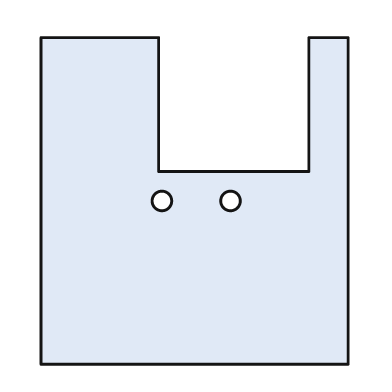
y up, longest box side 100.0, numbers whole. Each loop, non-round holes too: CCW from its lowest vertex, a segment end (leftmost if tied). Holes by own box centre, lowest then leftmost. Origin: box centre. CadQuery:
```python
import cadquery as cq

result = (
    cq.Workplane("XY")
    .moveTo(-47.0, -50.0)
    .lineTo(47.0, -50.0)
    .lineTo(47.0, 50.0)
    .lineTo(35.0, 50.0)
    .lineTo(35.0, 9.0)
    .lineTo(-11.0, 9.0)
    .lineTo(-11.0, 50.0)
    .lineTo(-47.0, 50.0)
    .close()
    .moveTo(-10.0, 0.0)
    .circle(3.0)
    .moveTo(11.0, 0.0)
    .circle(3.0)
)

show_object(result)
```